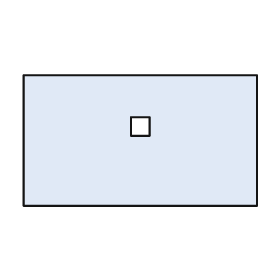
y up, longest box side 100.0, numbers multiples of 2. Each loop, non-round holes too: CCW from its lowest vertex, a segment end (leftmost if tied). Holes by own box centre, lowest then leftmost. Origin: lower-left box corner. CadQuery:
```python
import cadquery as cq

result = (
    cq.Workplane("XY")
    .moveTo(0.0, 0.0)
    .lineTo(100.0, 0.0)
    .lineTo(100.0, 56.0)
    .lineTo(0.0, 56.0)
    .close()
    .moveTo(46.0, 30.0)
    .lineTo(54.0, 30.0)
    .lineTo(54.0, 38.0)
    .lineTo(46.0, 38.0)
    .close()
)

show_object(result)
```